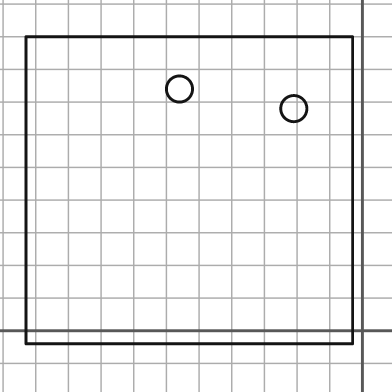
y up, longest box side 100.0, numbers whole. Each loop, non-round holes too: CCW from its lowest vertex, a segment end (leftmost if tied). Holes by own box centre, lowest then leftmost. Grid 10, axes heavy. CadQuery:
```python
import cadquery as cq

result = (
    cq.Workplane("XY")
    .moveTo(-103.0, -4.0)
    .lineTo(-3.0, -4.0)
    .lineTo(-3.0, 90.0)
    .lineTo(-103.0, 90.0)
    .close()
    .moveTo(-21.0, 68.0)
    .circle(4.0)
    .moveTo(-56.0, 74.0)
    .circle(4.0)
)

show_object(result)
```